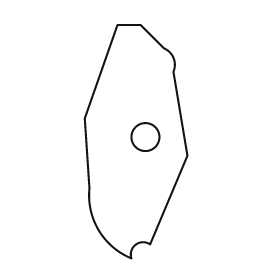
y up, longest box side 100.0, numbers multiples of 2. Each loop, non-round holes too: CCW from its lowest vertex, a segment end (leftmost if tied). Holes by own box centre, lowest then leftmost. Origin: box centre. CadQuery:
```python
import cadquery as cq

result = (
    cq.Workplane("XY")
    .moveTo(-2.0, -50.0)
    .threePointArc((0.0, -44.0), (6.0, -44.0))
    .lineTo(22.0, -6.0)
    .lineTo(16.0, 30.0)
    .threePointArc((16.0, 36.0), (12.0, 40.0))
    .lineTo(2.0, 50.0)
    .lineTo(-8.0, 50.0)
    .lineTo(-22.0, 10.0)
    .lineTo(-20.0, -20.0)
    .threePointArc((-16.0, -38.0), (-2.0, -50.0))
    .close()
    .moveTo(4.0, 2.0)
    .circle(6.0)
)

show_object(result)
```